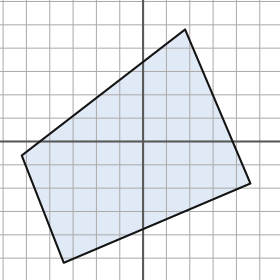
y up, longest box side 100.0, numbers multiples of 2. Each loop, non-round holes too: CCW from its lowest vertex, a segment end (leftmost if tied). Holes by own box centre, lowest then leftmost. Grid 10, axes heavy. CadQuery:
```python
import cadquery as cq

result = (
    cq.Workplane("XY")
    .moveTo(-34.0, -52.0)
    .lineTo(46.0, -18.0)
    .lineTo(18.0, 48.0)
    .lineTo(-52.0, -6.0)
    .close()
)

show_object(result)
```